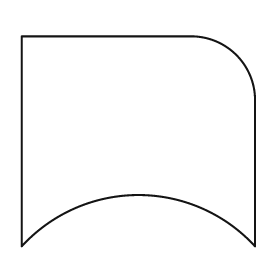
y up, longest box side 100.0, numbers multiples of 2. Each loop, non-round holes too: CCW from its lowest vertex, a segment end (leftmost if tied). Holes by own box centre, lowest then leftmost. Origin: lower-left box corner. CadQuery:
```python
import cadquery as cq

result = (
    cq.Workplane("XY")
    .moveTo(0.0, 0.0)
    .threePointArc((50.0, 22.0), (100.0, 0.0))
    .lineTo(100.0, 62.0)
    .threePointArc((92.0, 82.0), (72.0, 90.0))
    .lineTo(0.0, 90.0)
    .close()
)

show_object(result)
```